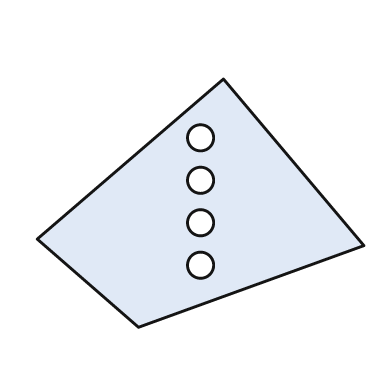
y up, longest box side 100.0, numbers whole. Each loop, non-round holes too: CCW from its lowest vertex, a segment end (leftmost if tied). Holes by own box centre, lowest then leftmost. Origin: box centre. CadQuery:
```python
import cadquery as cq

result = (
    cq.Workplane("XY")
    .moveTo(-19.0, -38.0)
    .lineTo(50.0, -13.0)
    .lineTo(7.0, 38.0)
    .lineTo(-50.0, -11.0)
    .close()
    .moveTo(0.0, -19.0)
    .circle(4.0)
    .moveTo(0.0, -6.0)
    .circle(4.0)
    .moveTo(0.0, 7.0)
    .circle(4.0)
    .moveTo(0.0, 20.0)
    .circle(4.0)
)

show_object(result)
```